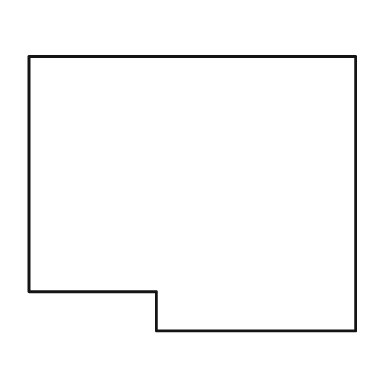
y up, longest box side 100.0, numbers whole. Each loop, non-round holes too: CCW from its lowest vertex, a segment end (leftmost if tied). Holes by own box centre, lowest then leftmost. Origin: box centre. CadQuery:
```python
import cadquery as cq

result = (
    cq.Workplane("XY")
    .moveTo(-11.0, -42.0)
    .lineTo(50.0, -42.0)
    .lineTo(50.0, 42.0)
    .lineTo(-50.0, 42.0)
    .lineTo(-50.0, -30.0)
    .lineTo(-11.0, -30.0)
    .close()
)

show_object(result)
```